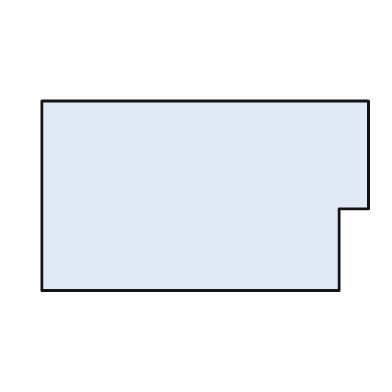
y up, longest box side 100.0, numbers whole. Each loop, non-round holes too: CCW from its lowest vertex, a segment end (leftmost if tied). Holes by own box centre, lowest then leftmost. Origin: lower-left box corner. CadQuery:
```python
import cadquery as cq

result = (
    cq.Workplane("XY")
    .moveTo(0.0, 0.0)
    .lineTo(91.0, 0.0)
    .lineTo(91.0, 25.0)
    .lineTo(100.0, 25.0)
    .lineTo(100.0, 58.0)
    .lineTo(0.0, 58.0)
    .close()
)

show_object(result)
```